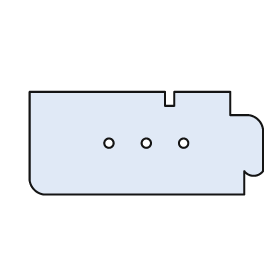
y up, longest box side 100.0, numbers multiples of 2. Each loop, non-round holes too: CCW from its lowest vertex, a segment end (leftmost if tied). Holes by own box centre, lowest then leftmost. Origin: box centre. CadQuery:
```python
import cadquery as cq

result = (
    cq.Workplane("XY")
    .moveTo(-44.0, -22.0)
    .lineTo(42.0, -22.0)
    .lineTo(42.0, -12.0)
    .threePointArc((46.0, -14.0), (50.0, -12.0))
    .lineTo(50.0, 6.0)
    .threePointArc((48.0, 10.0), (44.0, 12.0))
    .lineTo(36.0, 12.0)
    .lineTo(36.0, 22.0)
    .lineTo(12.0, 22.0)
    .lineTo(12.0, 16.0)
    .lineTo(8.0, 16.0)
    .lineTo(8.0, 22.0)
    .lineTo(-50.0, 22.0)
    .lineTo(-50.0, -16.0)
    .threePointArc((-48.0, -20.0), (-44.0, -22.0))
    .close()
    .moveTo(-16.0, 0.0)
    .circle(2.0)
    .moveTo(0.0, 0.0)
    .circle(2.0)
    .moveTo(16.0, 0.0)
    .circle(2.0)
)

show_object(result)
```